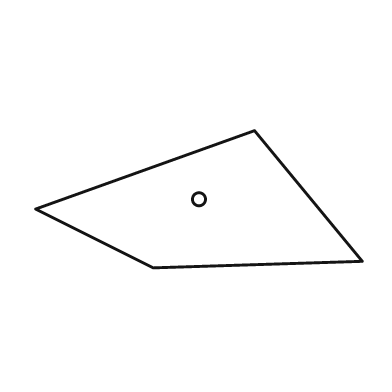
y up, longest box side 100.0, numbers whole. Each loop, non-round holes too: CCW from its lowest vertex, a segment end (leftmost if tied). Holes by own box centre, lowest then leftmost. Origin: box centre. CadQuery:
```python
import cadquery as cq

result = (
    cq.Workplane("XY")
    .moveTo(-14.0, -21.0)
    .lineTo(50.0, -19.0)
    .lineTo(17.0, 21.0)
    .lineTo(-50.0, -3.0)
    .close()
    .moveTo(0.0, 0.0)
    .circle(2.0)
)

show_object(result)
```